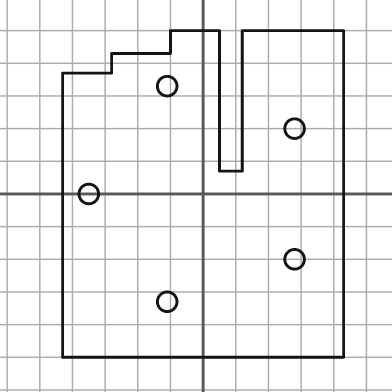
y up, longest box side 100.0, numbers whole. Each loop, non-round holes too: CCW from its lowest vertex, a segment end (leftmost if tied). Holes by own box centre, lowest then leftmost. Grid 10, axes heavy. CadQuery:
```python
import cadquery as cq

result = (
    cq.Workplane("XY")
    .moveTo(-43.0, -50.0)
    .lineTo(43.0, -50.0)
    .lineTo(43.0, 50.0)
    .lineTo(12.0, 50.0)
    .lineTo(12.0, 7.0)
    .lineTo(5.0, 7.0)
    .lineTo(5.0, 50.0)
    .lineTo(-10.0, 50.0)
    .lineTo(-10.0, 43.0)
    .lineTo(-28.0, 43.0)
    .lineTo(-28.0, 37.0)
    .lineTo(-43.0, 37.0)
    .close()
    .moveTo(-11.0, -33.0)
    .circle(3.0)
    .moveTo(28.0, -20.0)
    .circle(3.0)
    .moveTo(-35.0, 0.0)
    .circle(3.0)
    .moveTo(28.0, 20.0)
    .circle(3.0)
    .moveTo(-11.0, 33.0)
    .circle(3.0)
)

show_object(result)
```